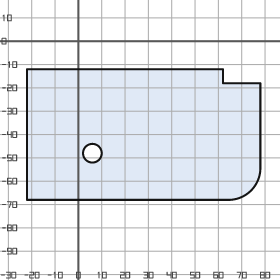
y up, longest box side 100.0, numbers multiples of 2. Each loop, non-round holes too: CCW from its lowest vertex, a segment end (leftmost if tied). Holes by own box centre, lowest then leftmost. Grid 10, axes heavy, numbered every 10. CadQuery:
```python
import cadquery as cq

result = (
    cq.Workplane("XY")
    .moveTo(-22.0, -68.0)
    .lineTo(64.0, -68.0)
    .threePointArc((74.0, -64.0), (78.0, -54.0))
    .lineTo(78.0, -18.0)
    .lineTo(62.0, -18.0)
    .lineTo(62.0, -12.0)
    .lineTo(-22.0, -12.0)
    .close()
    .moveTo(6.0, -48.0)
    .circle(4.0)
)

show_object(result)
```